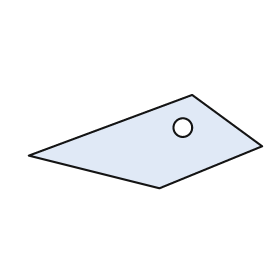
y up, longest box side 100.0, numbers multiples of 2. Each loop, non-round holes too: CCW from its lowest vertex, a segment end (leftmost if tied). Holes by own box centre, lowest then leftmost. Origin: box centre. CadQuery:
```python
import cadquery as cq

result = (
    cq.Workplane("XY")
    .moveTo(6.0, -20.0)
    .lineTo(50.0, -2.0)
    .lineTo(20.0, 20.0)
    .lineTo(-50.0, -6.0)
    .close()
    .moveTo(16.0, 6.0)
    .circle(4.0)
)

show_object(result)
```